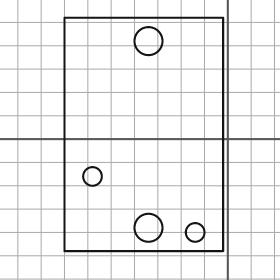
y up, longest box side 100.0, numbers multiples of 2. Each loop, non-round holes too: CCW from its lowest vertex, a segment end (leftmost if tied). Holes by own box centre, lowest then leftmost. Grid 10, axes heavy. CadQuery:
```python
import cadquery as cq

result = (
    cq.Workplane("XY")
    .moveTo(-70.0, -48.0)
    .lineTo(-2.0, -48.0)
    .lineTo(-2.0, 52.0)
    .lineTo(-70.0, 52.0)
    .close()
    .moveTo(-14.0, -40.0)
    .circle(4.0)
    .moveTo(-34.0, -38.0)
    .circle(6.0)
    .moveTo(-58.0, -16.0)
    .circle(4.0)
    .moveTo(-34.0, 42.0)
    .circle(6.0)
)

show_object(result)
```